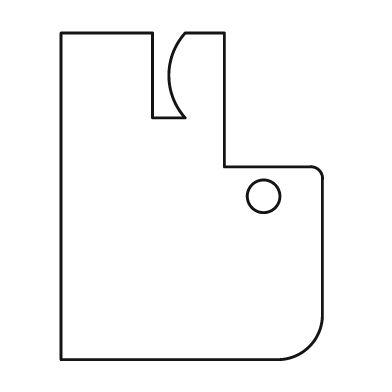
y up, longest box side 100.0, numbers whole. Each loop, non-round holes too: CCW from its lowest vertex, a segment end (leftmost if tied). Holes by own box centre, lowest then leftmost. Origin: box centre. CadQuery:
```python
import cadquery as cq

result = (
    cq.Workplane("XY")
    .moveTo(-40.0, -50.0)
    .lineTo(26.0, -50.0)
    .threePointArc((36.0, -46.0), (40.0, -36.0))
    .lineTo(40.0, 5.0)
    .threePointArc((39.0, 8.0), (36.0, 9.0))
    .lineTo(10.0, 9.0)
    .lineTo(10.0, 50.0)
    .lineTo(-2.0, 50.0)
    .threePointArc((-7.0, 37.0), (-2.0, 24.0))
    .lineTo(-12.0, 24.0)
    .lineTo(-12.0, 50.0)
    .lineTo(-40.0, 50.0)
    .close()
    .moveTo(22.0, 0.0)
    .circle(5.0)
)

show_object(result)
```